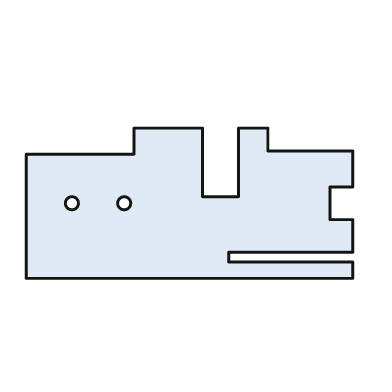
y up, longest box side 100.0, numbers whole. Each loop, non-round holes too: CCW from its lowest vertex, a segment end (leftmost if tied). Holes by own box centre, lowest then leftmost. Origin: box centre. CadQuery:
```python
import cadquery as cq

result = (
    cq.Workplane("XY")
    .moveTo(-50.0, -23.0)
    .lineTo(50.0, -23.0)
    .lineTo(50.0, -18.0)
    .lineTo(12.0, -18.0)
    .lineTo(12.0, -15.0)
    .lineTo(50.0, -15.0)
    .lineTo(50.0, -5.0)
    .lineTo(43.0, -5.0)
    .lineTo(43.0, 5.0)
    .lineTo(50.0, 5.0)
    .lineTo(50.0, 16.0)
    .lineTo(24.0, 16.0)
    .lineTo(24.0, 23.0)
    .lineTo(15.0, 23.0)
    .lineTo(15.0, 2.0)
    .lineTo(4.0, 2.0)
    .lineTo(4.0, 23.0)
    .lineTo(-17.0, 23.0)
    .lineTo(-17.0, 15.0)
    .lineTo(-50.0, 15.0)
    .close()
    .moveTo(-36.0, 0.0)
    .circle(2.0)
    .moveTo(-20.0, 0.0)
    .circle(2.0)
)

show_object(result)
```